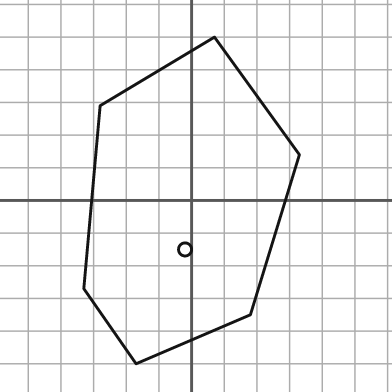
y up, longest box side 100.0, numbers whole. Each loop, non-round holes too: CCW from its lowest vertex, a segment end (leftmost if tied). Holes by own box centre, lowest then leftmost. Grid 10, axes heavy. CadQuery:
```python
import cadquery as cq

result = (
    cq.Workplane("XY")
    .moveTo(-17.0, -50.0)
    .lineTo(18.0, -35.0)
    .lineTo(33.0, 14.0)
    .lineTo(7.0, 50.0)
    .lineTo(-28.0, 29.0)
    .lineTo(-33.0, -27.0)
    .close()
    .moveTo(-2.0, -15.0)
    .circle(2.0)
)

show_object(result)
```